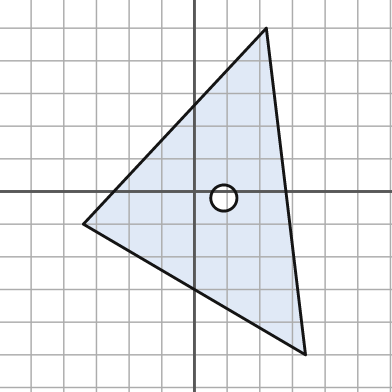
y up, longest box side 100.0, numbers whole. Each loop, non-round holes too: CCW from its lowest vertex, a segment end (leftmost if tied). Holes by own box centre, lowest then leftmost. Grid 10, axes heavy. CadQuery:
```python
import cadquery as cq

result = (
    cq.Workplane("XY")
    .moveTo(34.0, -50.0)
    .lineTo(22.0, 50.0)
    .lineTo(-34.0, -10.0)
    .close()
    .moveTo(9.0, -2.0)
    .circle(4.0)
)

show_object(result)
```